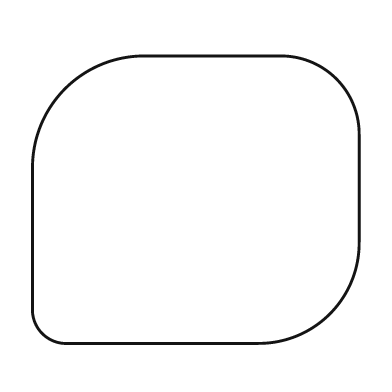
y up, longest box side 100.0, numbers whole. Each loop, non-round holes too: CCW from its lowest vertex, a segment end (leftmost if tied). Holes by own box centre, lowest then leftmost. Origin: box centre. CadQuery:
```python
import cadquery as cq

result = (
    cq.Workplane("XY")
    .moveTo(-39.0, -44.0)
    .lineTo(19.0, -44.0)
    .threePointArc((41.0, -35.0), (50.0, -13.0))
    .lineTo(50.0, 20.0)
    .threePointArc((43.0, 37.0), (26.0, 44.0))
    .lineTo(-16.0, 44.0)
    .threePointArc((-40.0, 34.0), (-50.0, 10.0))
    .lineTo(-50.0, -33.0)
    .threePointArc((-47.0, -41.0), (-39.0, -44.0))
    .close()
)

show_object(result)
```